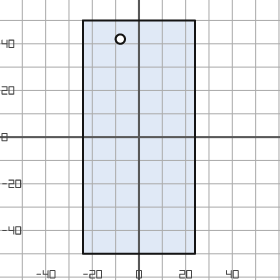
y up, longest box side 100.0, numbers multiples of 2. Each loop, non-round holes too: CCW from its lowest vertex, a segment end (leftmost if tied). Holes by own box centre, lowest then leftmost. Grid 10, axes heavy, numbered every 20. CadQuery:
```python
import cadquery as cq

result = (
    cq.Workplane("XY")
    .moveTo(-24.0, -50.0)
    .lineTo(24.0, -50.0)
    .lineTo(24.0, 50.0)
    .lineTo(-24.0, 50.0)
    .close()
    .moveTo(-8.0, 42.0)
    .circle(2.0)
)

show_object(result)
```